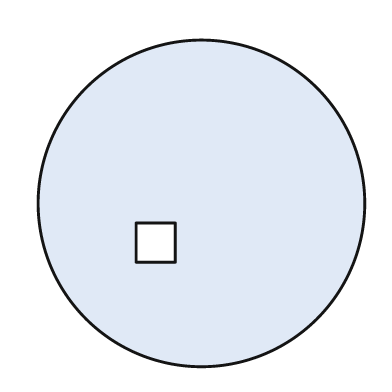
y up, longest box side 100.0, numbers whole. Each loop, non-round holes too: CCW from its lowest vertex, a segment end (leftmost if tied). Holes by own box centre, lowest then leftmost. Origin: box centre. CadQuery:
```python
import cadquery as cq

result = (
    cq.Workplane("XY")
    .moveTo(0.0, 0.0)
    .circle(50.0)
    .moveTo(-20.0, -18.0)
    .lineTo(-8.0, -18.0)
    .lineTo(-8.0, -6.0)
    .lineTo(-20.0, -6.0)
    .close()
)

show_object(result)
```